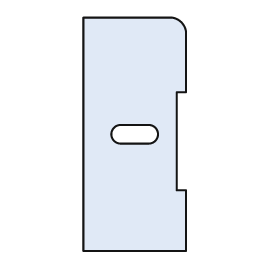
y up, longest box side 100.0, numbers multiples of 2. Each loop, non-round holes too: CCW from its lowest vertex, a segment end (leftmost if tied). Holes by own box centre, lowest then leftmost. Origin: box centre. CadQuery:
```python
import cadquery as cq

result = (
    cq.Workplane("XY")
    .moveTo(-22.0, -50.0)
    .lineTo(22.0, -50.0)
    .lineTo(22.0, -24.0)
    .lineTo(18.0, -24.0)
    .lineTo(18.0, 18.0)
    .lineTo(22.0, 18.0)
    .lineTo(22.0, 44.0)
    .threePointArc((20.0, 48.0), (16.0, 50.0))
    .lineTo(-22.0, 50.0)
    .close()
    .moveTo(-6.0, -4.0)
    .lineTo(6.0, -4.0)
    .threePointArc((10.0, 0.0), (6.0, 4.0))
    .lineTo(-6.0, 4.0)
    .threePointArc((-10.0, 0.0), (-6.0, -4.0))
    .close()
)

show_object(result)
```